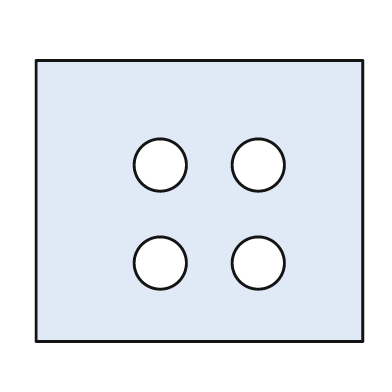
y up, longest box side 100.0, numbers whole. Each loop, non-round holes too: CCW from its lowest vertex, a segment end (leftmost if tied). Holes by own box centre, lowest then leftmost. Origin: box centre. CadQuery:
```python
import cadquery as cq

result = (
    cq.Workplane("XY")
    .moveTo(-50.0, -43.0)
    .lineTo(50.0, -43.0)
    .lineTo(50.0, 43.0)
    .lineTo(-50.0, 43.0)
    .close()
    .moveTo(-12.0, -19.0)
    .circle(8.0)
    .moveTo(18.0, -19.0)
    .circle(8.0)
    .moveTo(-12.0, 11.0)
    .circle(8.0)
    .moveTo(18.0, 11.0)
    .circle(8.0)
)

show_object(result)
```